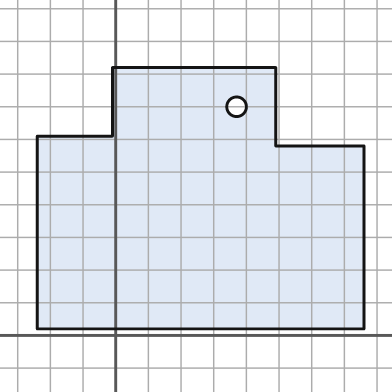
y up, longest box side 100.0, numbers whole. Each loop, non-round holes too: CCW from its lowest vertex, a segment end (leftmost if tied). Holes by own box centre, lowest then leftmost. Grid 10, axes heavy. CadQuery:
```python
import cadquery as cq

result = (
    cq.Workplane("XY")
    .moveTo(-24.0, 2.0)
    .lineTo(76.0, 2.0)
    .lineTo(76.0, 58.0)
    .lineTo(49.0, 58.0)
    .lineTo(49.0, 82.0)
    .lineTo(-1.0, 82.0)
    .lineTo(-1.0, 61.0)
    .lineTo(-24.0, 61.0)
    .close()
    .moveTo(37.0, 70.0)
    .circle(3.0)
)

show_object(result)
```